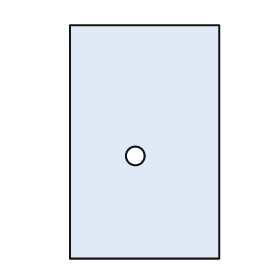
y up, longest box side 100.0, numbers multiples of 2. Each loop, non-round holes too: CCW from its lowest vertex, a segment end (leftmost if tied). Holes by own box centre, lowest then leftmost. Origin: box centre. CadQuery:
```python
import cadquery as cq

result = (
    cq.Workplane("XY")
    .moveTo(-32.0, -50.0)
    .lineTo(32.0, -50.0)
    .lineTo(32.0, 50.0)
    .lineTo(-32.0, 50.0)
    .close()
    .moveTo(-4.0, -6.0)
    .circle(4.0)
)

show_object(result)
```